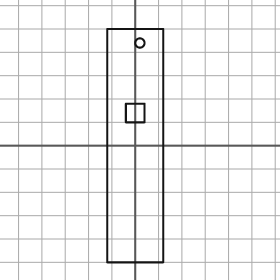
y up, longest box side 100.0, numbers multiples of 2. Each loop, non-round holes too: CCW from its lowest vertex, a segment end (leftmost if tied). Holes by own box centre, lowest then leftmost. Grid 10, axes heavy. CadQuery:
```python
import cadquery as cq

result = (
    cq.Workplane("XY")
    .moveTo(-12.0, -50.0)
    .lineTo(12.0, -50.0)
    .lineTo(12.0, 50.0)
    .lineTo(-12.0, 50.0)
    .close()
    .moveTo(-4.0, 10.0)
    .lineTo(4.0, 10.0)
    .lineTo(4.0, 18.0)
    .lineTo(-4.0, 18.0)
    .close()
    .moveTo(2.0, 44.0)
    .circle(2.0)
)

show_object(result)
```